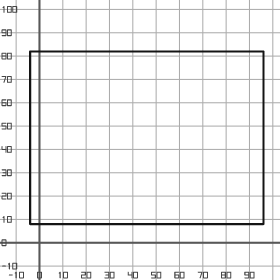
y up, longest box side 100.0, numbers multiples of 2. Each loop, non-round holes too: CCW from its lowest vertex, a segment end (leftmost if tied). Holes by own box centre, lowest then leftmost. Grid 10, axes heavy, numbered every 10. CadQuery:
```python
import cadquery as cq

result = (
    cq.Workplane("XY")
    .moveTo(-4.0, 8.0)
    .lineTo(96.0, 8.0)
    .lineTo(96.0, 82.0)
    .lineTo(-4.0, 82.0)
    .close()
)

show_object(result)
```